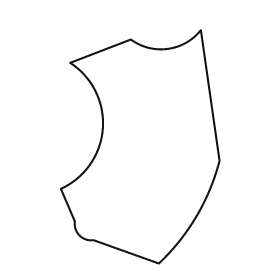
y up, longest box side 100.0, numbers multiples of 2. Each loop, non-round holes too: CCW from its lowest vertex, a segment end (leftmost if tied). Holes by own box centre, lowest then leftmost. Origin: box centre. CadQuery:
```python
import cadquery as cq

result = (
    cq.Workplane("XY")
    .moveTo(8.0, -50.0)
    .threePointArc((24.0, -30.0), (34.0, -6.0))
    .lineTo(26.0, 50.0)
    .threePointArc((12.0, 42.0), (-4.0, 46.0))
    .lineTo(-30.0, 36.0)
    .threePointArc((-16.0, 8.0), (-34.0, -18.0))
    .lineTo(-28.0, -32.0)
    .threePointArc((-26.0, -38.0), (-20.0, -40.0))
    .close()
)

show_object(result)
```